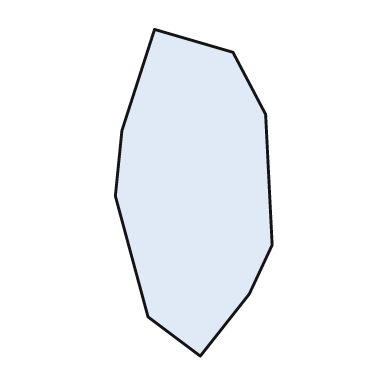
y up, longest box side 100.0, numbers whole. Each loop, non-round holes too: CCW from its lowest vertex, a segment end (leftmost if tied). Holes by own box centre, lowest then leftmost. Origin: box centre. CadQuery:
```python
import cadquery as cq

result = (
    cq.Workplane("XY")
    .moveTo(2.0, -50.0)
    .lineTo(17.0, -31.0)
    .lineTo(24.0, -16.0)
    .lineTo(22.0, 24.0)
    .lineTo(12.0, 43.0)
    .lineTo(-12.0, 50.0)
    .lineTo(-22.0, 19.0)
    .lineTo(-24.0, -1.0)
    .lineTo(-14.0, -38.0)
    .close()
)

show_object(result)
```